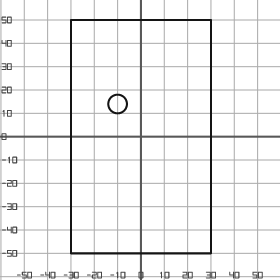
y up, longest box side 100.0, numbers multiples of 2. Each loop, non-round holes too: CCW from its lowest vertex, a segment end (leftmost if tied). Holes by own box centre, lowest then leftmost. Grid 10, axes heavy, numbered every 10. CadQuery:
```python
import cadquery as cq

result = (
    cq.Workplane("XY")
    .moveTo(-30.0, -50.0)
    .lineTo(30.0, -50.0)
    .lineTo(30.0, 50.0)
    .lineTo(-30.0, 50.0)
    .close()
    .moveTo(-10.0, 14.0)
    .circle(4.0)
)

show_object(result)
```